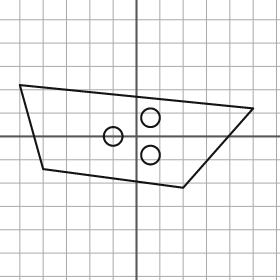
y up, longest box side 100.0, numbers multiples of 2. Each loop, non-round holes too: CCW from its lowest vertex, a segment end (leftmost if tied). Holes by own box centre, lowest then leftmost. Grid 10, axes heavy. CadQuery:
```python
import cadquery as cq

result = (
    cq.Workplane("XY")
    .moveTo(20.0, -22.0)
    .lineTo(50.0, 12.0)
    .lineTo(-50.0, 22.0)
    .lineTo(-40.0, -14.0)
    .close()
    .moveTo(6.0, -8.0)
    .circle(4.0)
    .moveTo(-10.0, 0.0)
    .circle(4.0)
    .moveTo(6.0, 8.0)
    .circle(4.0)
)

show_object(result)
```